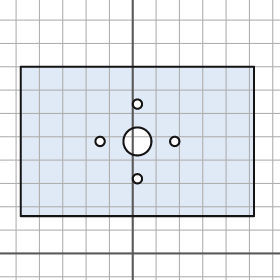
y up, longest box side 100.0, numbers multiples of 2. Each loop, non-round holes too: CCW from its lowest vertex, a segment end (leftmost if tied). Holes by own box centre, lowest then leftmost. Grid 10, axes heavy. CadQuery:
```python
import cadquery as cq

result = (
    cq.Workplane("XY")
    .moveTo(-48.0, 16.0)
    .lineTo(52.0, 16.0)
    .lineTo(52.0, 80.0)
    .lineTo(-48.0, 80.0)
    .close()
    .moveTo(2.0, 32.0)
    .circle(2.0)
    .moveTo(-14.0, 48.0)
    .circle(2.0)
    .moveTo(2.0, 48.0)
    .circle(6.0)
    .moveTo(18.0, 48.0)
    .circle(2.0)
    .moveTo(2.0, 64.0)
    .circle(2.0)
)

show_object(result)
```